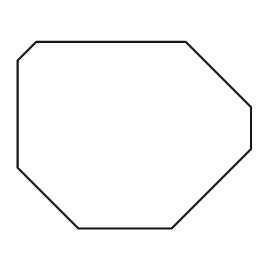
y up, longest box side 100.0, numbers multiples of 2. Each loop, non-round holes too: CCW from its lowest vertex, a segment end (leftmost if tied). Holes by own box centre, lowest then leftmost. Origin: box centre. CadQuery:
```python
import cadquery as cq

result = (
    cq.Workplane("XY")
    .moveTo(-24.0, -40.0)
    .lineTo(16.0, -40.0)
    .lineTo(50.0, -6.0)
    .lineTo(50.0, 12.0)
    .lineTo(22.0, 40.0)
    .lineTo(-42.0, 40.0)
    .lineTo(-50.0, 32.0)
    .lineTo(-50.0, -14.0)
    .close()
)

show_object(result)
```